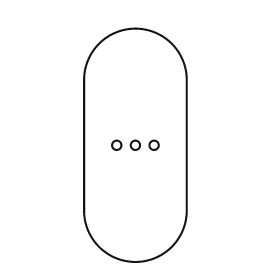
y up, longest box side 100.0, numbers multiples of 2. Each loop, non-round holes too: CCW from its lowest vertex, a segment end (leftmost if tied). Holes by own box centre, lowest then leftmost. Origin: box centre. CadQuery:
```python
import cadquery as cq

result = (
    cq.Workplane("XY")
    .moveTo(-22.0, -28.0)
    .threePointArc((0.0, -50.0), (22.0, -28.0))
    .lineTo(22.0, 28.0)
    .threePointArc((0.0, 50.0), (-22.0, 28.0))
    .close()
    .moveTo(-8.0, 0.0)
    .circle(2.0)
    .moveTo(0.0, 0.0)
    .circle(2.0)
    .moveTo(8.0, 0.0)
    .circle(2.0)
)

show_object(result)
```